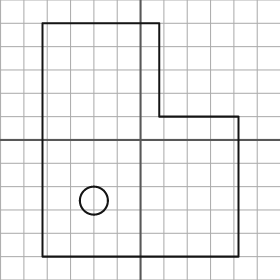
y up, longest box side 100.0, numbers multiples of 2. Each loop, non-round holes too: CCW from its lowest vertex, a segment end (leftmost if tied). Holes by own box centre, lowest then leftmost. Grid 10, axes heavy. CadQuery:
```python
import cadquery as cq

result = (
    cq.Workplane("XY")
    .moveTo(-42.0, -50.0)
    .lineTo(42.0, -50.0)
    .lineTo(42.0, 10.0)
    .lineTo(8.0, 10.0)
    .lineTo(8.0, 50.0)
    .lineTo(-42.0, 50.0)
    .close()
    .moveTo(-20.0, -26.0)
    .circle(6.0)
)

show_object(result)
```